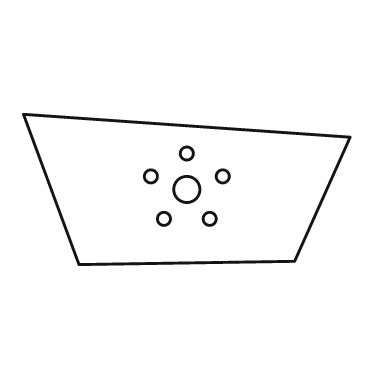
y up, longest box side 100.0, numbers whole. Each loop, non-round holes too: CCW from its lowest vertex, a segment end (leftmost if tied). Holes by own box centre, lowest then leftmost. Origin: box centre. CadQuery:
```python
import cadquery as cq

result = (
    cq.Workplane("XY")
    .moveTo(-33.0, -23.0)
    .lineTo(33.0, -22.0)
    .lineTo(50.0, 16.0)
    .lineTo(-50.0, 23.0)
    .close()
    .moveTo(-7.0, -9.0)
    .circle(2.0)
    .moveTo(7.0, -9.0)
    .circle(2.0)
    .moveTo(0.0, 0.0)
    .circle(4.0)
    .moveTo(-11.0, 4.0)
    .circle(2.0)
    .moveTo(11.0, 4.0)
    .circle(2.0)
    .moveTo(0.0, 11.0)
    .circle(2.0)
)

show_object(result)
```